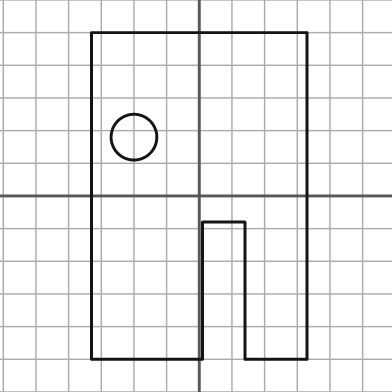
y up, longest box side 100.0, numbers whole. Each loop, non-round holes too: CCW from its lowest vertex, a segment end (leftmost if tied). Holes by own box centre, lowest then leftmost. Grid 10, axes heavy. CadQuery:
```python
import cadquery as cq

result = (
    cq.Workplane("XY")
    .moveTo(-33.0, -50.0)
    .lineTo(1.0, -50.0)
    .lineTo(1.0, -8.0)
    .lineTo(14.0, -8.0)
    .lineTo(14.0, -50.0)
    .lineTo(33.0, -50.0)
    .lineTo(33.0, 50.0)
    .lineTo(-33.0, 50.0)
    .close()
    .moveTo(-20.0, 18.0)
    .circle(7.0)
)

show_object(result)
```